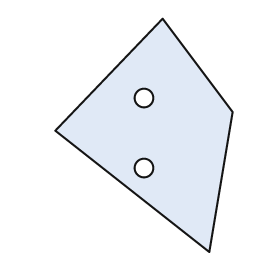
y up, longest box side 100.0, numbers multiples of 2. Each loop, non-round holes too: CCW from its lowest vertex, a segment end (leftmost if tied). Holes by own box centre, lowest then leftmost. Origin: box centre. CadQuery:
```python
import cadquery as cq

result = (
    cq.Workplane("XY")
    .moveTo(28.0, -50.0)
    .lineTo(38.0, 10.0)
    .lineTo(8.0, 50.0)
    .lineTo(-38.0, 2.0)
    .close()
    .moveTo(0.0, -14.0)
    .circle(4.0)
    .moveTo(0.0, 16.0)
    .circle(4.0)
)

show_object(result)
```